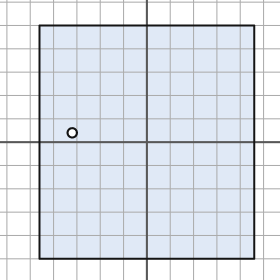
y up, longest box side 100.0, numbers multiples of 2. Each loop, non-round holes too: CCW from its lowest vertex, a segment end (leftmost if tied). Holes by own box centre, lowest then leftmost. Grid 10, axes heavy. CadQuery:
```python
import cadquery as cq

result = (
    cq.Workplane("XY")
    .moveTo(-46.0, -50.0)
    .lineTo(46.0, -50.0)
    .lineTo(46.0, 50.0)
    .lineTo(-46.0, 50.0)
    .close()
    .moveTo(-32.0, 4.0)
    .circle(2.0)
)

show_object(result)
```